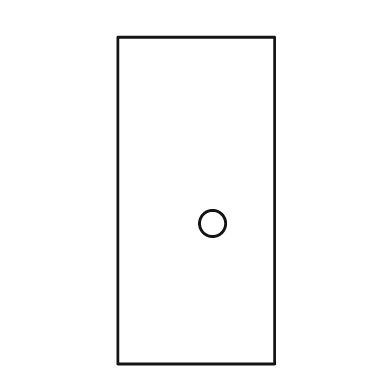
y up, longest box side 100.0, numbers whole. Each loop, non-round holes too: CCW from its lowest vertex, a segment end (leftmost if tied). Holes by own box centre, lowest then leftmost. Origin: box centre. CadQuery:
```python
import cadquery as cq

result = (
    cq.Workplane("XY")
    .moveTo(-24.0, -50.0)
    .lineTo(24.0, -50.0)
    .lineTo(24.0, 50.0)
    .lineTo(-24.0, 50.0)
    .close()
    .moveTo(5.0, -7.0)
    .circle(4.0)
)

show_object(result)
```